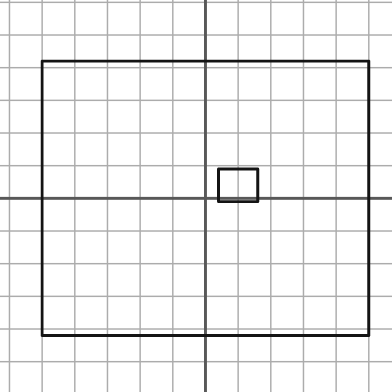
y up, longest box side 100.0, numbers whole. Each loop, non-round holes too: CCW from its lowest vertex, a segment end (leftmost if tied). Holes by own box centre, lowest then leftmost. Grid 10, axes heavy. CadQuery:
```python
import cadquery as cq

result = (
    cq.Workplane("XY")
    .moveTo(-50.0, -42.0)
    .lineTo(50.0, -42.0)
    .lineTo(50.0, 42.0)
    .lineTo(-50.0, 42.0)
    .close()
    .moveTo(4.0, -1.0)
    .lineTo(16.0, -1.0)
    .lineTo(16.0, 9.0)
    .lineTo(4.0, 9.0)
    .close()
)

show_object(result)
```